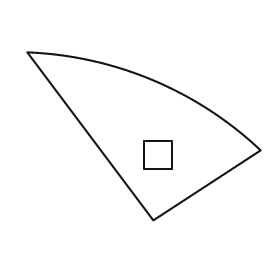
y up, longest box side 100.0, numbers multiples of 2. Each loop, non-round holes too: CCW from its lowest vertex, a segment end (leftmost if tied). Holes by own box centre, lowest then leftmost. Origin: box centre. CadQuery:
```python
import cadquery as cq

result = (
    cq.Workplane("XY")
    .moveTo(4.0, -36.0)
    .lineTo(50.0, -6.0)
    .threePointArc((4.0, 24.0), (-50.0, 36.0))
    .close()
    .moveTo(0.0, -14.0)
    .lineTo(12.0, -14.0)
    .lineTo(12.0, -2.0)
    .lineTo(0.0, -2.0)
    .close()
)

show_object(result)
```